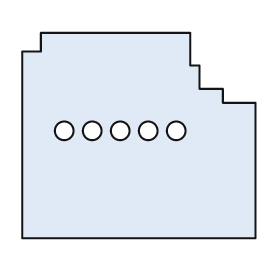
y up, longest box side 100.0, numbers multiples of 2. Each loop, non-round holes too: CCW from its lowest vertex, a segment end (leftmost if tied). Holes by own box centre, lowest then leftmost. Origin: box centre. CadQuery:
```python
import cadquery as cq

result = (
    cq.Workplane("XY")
    .moveTo(-50.0, -44.0)
    .lineTo(50.0, -44.0)
    .lineTo(50.0, 14.0)
    .lineTo(36.0, 14.0)
    .lineTo(36.0, 20.0)
    .lineTo(26.0, 20.0)
    .lineTo(26.0, 30.0)
    .lineTo(22.0, 30.0)
    .lineTo(22.0, 44.0)
    .lineTo(-42.0, 44.0)
    .lineTo(-42.0, 36.0)
    .lineTo(-50.0, 36.0)
    .close()
    .moveTo(-32.0, 2.0)
    .circle(4.0)
    .moveTo(-20.0, 2.0)
    .circle(4.0)
    .moveTo(-8.0, 2.0)
    .circle(4.0)
    .moveTo(4.0, 2.0)
    .circle(4.0)
    .moveTo(16.0, 2.0)
    .circle(4.0)
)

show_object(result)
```